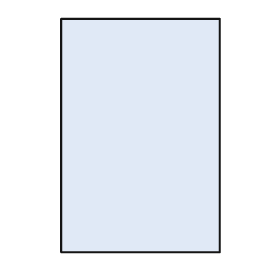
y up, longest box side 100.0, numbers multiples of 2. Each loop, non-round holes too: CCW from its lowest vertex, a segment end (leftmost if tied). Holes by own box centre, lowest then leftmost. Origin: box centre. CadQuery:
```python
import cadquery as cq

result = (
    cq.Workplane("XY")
    .moveTo(-34.0, -50.0)
    .lineTo(34.0, -50.0)
    .lineTo(34.0, 50.0)
    .lineTo(-34.0, 50.0)
    .close()
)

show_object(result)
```